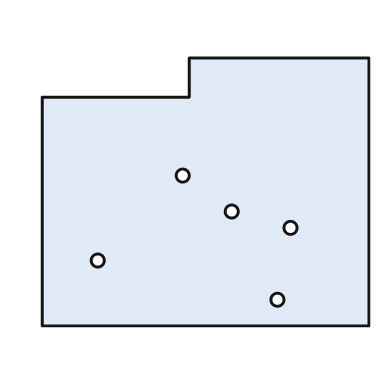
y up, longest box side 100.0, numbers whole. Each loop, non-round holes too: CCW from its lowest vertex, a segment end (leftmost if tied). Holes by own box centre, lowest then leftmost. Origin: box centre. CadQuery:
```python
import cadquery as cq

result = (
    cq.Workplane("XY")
    .moveTo(-50.0, -41.0)
    .lineTo(50.0, -41.0)
    .lineTo(50.0, 41.0)
    .lineTo(-5.0, 41.0)
    .lineTo(-5.0, 29.0)
    .lineTo(-50.0, 29.0)
    .close()
    .moveTo(22.0, -33.0)
    .circle(2.0)
    .moveTo(-33.0, -21.0)
    .circle(2.0)
    .moveTo(26.0, -11.0)
    .circle(2.0)
    .moveTo(8.0, -6.0)
    .circle(2.0)
    .moveTo(-7.0, 5.0)
    .circle(2.0)
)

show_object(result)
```